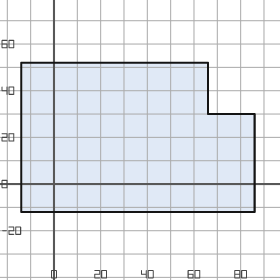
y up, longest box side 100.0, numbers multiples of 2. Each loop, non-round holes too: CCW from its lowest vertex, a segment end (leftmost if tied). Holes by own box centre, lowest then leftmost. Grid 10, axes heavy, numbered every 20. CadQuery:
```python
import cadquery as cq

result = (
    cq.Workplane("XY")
    .moveTo(-14.0, -12.0)
    .lineTo(86.0, -12.0)
    .lineTo(86.0, 30.0)
    .lineTo(66.0, 30.0)
    .lineTo(66.0, 52.0)
    .lineTo(-14.0, 52.0)
    .close()
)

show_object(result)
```